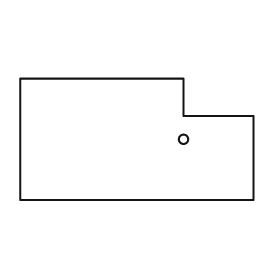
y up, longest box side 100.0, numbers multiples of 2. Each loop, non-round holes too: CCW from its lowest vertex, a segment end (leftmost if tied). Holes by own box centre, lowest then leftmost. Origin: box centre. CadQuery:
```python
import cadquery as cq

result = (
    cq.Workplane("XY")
    .moveTo(-50.0, -26.0)
    .lineTo(50.0, -26.0)
    .lineTo(50.0, 10.0)
    .lineTo(20.0, 10.0)
    .lineTo(20.0, 26.0)
    .lineTo(-50.0, 26.0)
    .close()
    .moveTo(20.0, 0.0)
    .circle(2.0)
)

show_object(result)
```